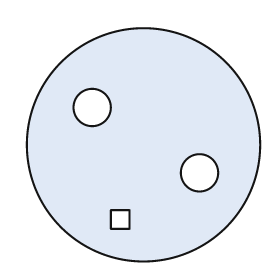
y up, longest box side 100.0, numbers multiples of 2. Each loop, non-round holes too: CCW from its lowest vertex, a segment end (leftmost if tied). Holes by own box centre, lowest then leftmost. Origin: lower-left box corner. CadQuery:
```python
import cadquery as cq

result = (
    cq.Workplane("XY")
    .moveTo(50.0, 50.0)
    .circle(50.0)
    .moveTo(36.0, 14.0)
    .lineTo(44.0, 14.0)
    .lineTo(44.0, 22.0)
    .lineTo(36.0, 22.0)
    .close()
    .moveTo(74.0, 38.0)
    .circle(8.0)
    .moveTo(28.0, 66.0)
    .circle(8.0)
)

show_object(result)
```